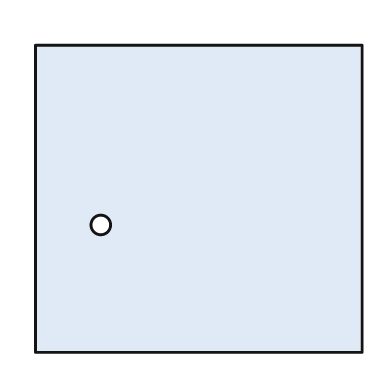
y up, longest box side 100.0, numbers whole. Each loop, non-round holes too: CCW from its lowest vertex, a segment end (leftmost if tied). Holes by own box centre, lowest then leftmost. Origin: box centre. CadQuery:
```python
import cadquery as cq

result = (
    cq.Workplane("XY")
    .moveTo(-50.0, -47.0)
    .lineTo(50.0, -47.0)
    .lineTo(50.0, 47.0)
    .lineTo(-50.0, 47.0)
    .close()
    .moveTo(-30.0, -8.0)
    .circle(3.0)
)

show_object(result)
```